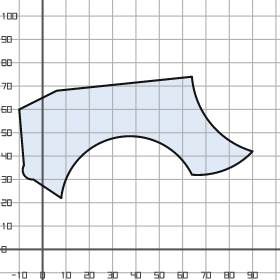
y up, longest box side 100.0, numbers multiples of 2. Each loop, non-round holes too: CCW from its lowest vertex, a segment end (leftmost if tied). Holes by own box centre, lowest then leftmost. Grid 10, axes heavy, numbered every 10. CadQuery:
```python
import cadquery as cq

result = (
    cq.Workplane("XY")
    .moveTo(8.0, 22.0)
    .threePointArc((32.0, 48.0), (64.0, 32.0))
    .threePointArc((78.0, 34.0), (90.0, 42.0))
    .threePointArc((72.0, 54.0), (64.0, 74.0))
    .lineTo(6.0, 68.0)
    .lineTo(-10.0, 60.0)
    .lineTo(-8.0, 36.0)
    .threePointArc((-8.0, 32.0), (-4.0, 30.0))
    .close()
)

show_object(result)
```